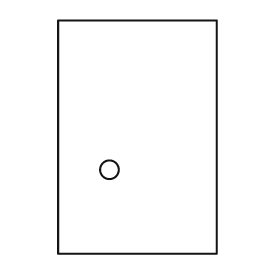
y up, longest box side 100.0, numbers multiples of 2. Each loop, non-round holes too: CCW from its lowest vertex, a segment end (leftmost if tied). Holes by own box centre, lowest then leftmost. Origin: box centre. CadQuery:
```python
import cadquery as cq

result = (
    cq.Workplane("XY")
    .moveTo(-34.0, -50.0)
    .lineTo(34.0, -50.0)
    .lineTo(34.0, 50.0)
    .lineTo(-34.0, 50.0)
    .close()
    .moveTo(-12.0, -14.0)
    .circle(4.0)
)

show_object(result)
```